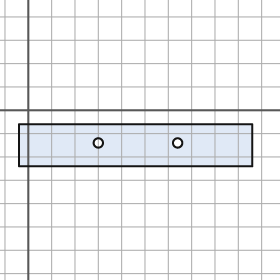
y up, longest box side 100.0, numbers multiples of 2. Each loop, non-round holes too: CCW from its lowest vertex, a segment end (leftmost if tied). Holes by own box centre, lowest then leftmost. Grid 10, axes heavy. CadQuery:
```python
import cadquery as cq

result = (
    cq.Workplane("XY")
    .moveTo(-4.0, -24.0)
    .lineTo(96.0, -24.0)
    .lineTo(96.0, -6.0)
    .lineTo(-4.0, -6.0)
    .close()
    .moveTo(30.0, -14.0)
    .circle(2.0)
    .moveTo(64.0, -14.0)
    .circle(2.0)
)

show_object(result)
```